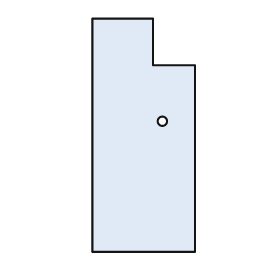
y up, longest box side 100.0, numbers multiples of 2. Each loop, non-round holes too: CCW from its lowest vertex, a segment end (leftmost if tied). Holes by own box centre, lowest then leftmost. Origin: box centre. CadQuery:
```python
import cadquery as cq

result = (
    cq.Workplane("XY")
    .moveTo(-22.0, -50.0)
    .lineTo(22.0, -50.0)
    .lineTo(22.0, 30.0)
    .lineTo(4.0, 30.0)
    .lineTo(4.0, 50.0)
    .lineTo(-22.0, 50.0)
    .close()
    .moveTo(8.0, 6.0)
    .circle(2.0)
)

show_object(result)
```